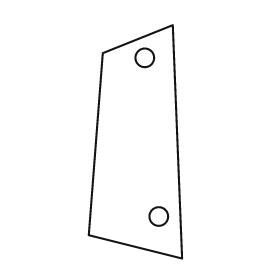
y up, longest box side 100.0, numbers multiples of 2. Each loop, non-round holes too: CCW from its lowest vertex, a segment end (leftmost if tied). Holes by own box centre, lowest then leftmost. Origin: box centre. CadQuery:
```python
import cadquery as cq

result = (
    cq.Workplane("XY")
    .moveTo(20.0, -50.0)
    .lineTo(16.0, 50.0)
    .lineTo(-14.0, 38.0)
    .lineTo(-20.0, -40.0)
    .close()
    .moveTo(10.0, -32.0)
    .circle(4.0)
    .moveTo(4.0, 36.0)
    .circle(4.0)
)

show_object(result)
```